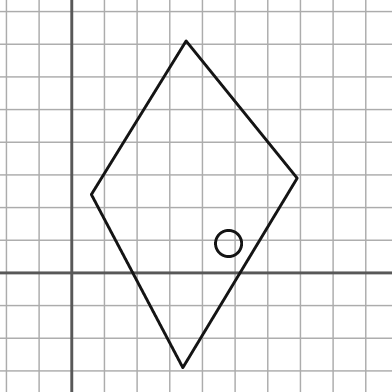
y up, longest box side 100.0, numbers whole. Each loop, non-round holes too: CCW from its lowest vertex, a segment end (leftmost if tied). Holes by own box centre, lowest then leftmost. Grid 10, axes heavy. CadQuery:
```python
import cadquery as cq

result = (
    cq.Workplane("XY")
    .moveTo(34.0, -29.0)
    .lineTo(69.0, 29.0)
    .lineTo(35.0, 71.0)
    .lineTo(6.0, 24.0)
    .close()
    .moveTo(48.0, 9.0)
    .circle(4.0)
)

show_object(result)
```